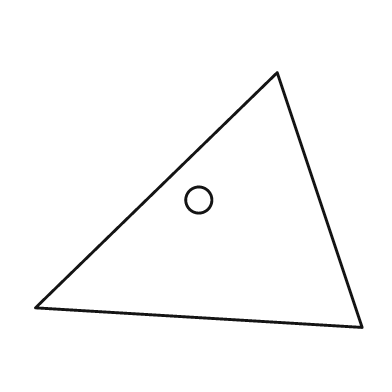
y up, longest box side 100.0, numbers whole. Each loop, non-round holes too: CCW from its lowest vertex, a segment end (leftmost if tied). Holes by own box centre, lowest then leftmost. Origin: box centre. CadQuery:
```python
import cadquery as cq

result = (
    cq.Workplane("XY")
    .moveTo(50.0, -39.0)
    .lineTo(24.0, 39.0)
    .lineTo(-50.0, -33.0)
    .close()
    .moveTo(0.0, 0.0)
    .circle(4.0)
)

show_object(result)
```